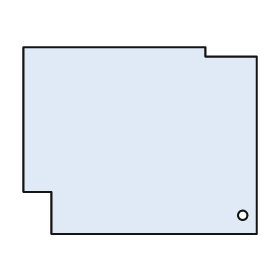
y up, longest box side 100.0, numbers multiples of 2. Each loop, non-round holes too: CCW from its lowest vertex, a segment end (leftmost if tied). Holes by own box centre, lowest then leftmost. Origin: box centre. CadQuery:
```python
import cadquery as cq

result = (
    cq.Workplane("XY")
    .moveTo(-38.0, -40.0)
    .lineTo(50.0, -40.0)
    .lineTo(50.0, 36.0)
    .lineTo(28.0, 36.0)
    .lineTo(28.0, 40.0)
    .lineTo(-50.0, 40.0)
    .lineTo(-50.0, -22.0)
    .lineTo(-38.0, -22.0)
    .close()
    .moveTo(44.0, -32.0)
    .circle(2.0)
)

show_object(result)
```